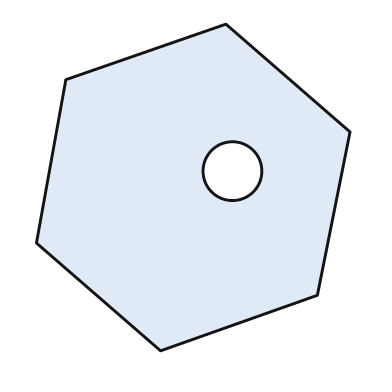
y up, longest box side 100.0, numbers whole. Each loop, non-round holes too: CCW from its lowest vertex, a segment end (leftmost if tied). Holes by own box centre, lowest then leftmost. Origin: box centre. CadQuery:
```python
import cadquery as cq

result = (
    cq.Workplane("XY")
    .moveTo(-10.0, -50.0)
    .lineTo(38.0, -33.0)
    .lineTo(48.0, 17.0)
    .lineTo(10.0, 50.0)
    .lineTo(-39.0, 33.0)
    .lineTo(-48.0, -17.0)
    .close()
    .moveTo(12.0, 5.0)
    .circle(9.0)
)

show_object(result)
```